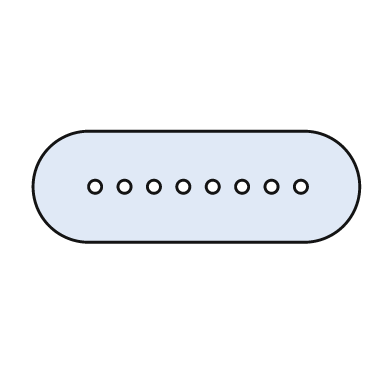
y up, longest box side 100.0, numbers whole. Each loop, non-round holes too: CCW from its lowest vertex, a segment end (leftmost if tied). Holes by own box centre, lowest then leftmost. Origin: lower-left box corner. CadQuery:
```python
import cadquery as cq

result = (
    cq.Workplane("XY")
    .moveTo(17.0, 0.0)
    .lineTo(83.0, 0.0)
    .threePointArc((100.0, 17.0), (83.0, 34.0))
    .lineTo(17.0, 34.0)
    .threePointArc((0.0, 17.0), (17.0, 0.0))
    .close()
    .moveTo(19.0, 17.0)
    .circle(2.0)
    .moveTo(28.0, 17.0)
    .circle(2.0)
    .moveTo(37.0, 17.0)
    .circle(2.0)
    .moveTo(46.0, 17.0)
    .circle(2.0)
    .moveTo(55.0, 17.0)
    .circle(2.0)
    .moveTo(64.0, 17.0)
    .circle(2.0)
    .moveTo(73.0, 17.0)
    .circle(2.0)
    .moveTo(82.0, 17.0)
    .circle(2.0)
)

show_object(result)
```